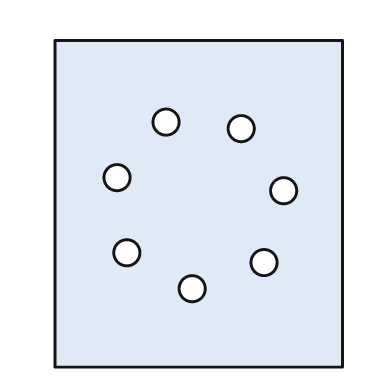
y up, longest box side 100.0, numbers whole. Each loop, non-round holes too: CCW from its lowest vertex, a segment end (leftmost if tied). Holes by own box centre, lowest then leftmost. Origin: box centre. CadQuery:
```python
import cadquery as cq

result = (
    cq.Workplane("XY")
    .moveTo(-44.0, -50.0)
    .lineTo(44.0, -50.0)
    .lineTo(44.0, 50.0)
    .lineTo(-44.0, 50.0)
    .close()
    .moveTo(-2.0, -26.0)
    .circle(4.0)
    .moveTo(20.0, -18.0)
    .circle(4.0)
    .moveTo(-22.0, -15.0)
    .circle(4.0)
    .moveTo(26.0, 4.0)
    .circle(4.0)
    .moveTo(-25.0, 8.0)
    .circle(4.0)
    .moveTo(13.0, 23.0)
    .circle(4.0)
    .moveTo(-10.0, 25.0)
    .circle(4.0)
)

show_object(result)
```